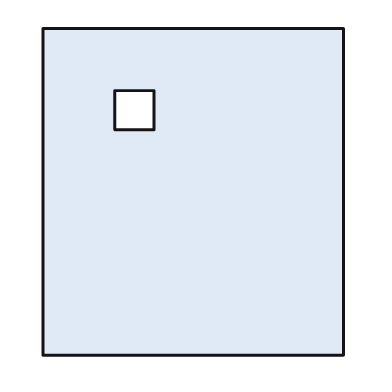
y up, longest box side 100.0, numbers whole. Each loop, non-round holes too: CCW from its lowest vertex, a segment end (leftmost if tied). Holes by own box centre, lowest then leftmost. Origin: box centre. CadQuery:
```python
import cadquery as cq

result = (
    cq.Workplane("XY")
    .moveTo(-46.0, -50.0)
    .lineTo(46.0, -50.0)
    .lineTo(46.0, 50.0)
    .lineTo(-46.0, 50.0)
    .close()
    .moveTo(-24.0, 19.0)
    .lineTo(-12.0, 19.0)
    .lineTo(-12.0, 31.0)
    .lineTo(-24.0, 31.0)
    .close()
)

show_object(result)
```